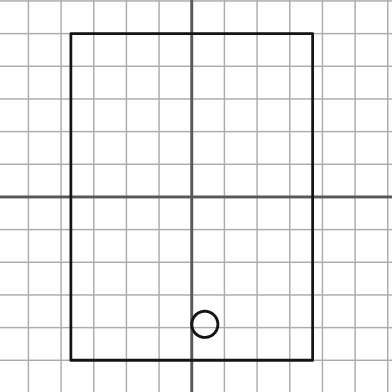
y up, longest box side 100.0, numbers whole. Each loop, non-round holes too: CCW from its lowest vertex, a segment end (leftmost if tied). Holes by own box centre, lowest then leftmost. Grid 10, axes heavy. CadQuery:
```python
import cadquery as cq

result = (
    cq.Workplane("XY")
    .moveTo(-37.0, -50.0)
    .lineTo(37.0, -50.0)
    .lineTo(37.0, 50.0)
    .lineTo(-37.0, 50.0)
    .close()
    .moveTo(4.0, -39.0)
    .circle(4.0)
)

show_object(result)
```